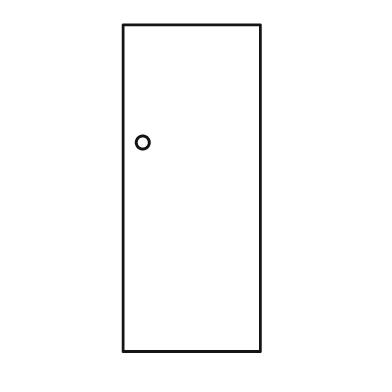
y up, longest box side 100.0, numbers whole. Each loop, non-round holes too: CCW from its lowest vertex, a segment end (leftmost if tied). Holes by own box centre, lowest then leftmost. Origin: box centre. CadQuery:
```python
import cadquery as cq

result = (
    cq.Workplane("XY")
    .moveTo(-21.0, -50.0)
    .lineTo(21.0, -50.0)
    .lineTo(21.0, 50.0)
    .lineTo(-21.0, 50.0)
    .close()
    .moveTo(-15.0, 14.0)
    .circle(2.0)
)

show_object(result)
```